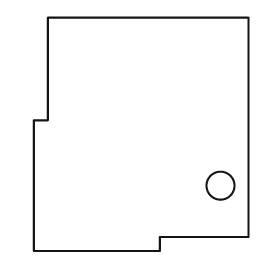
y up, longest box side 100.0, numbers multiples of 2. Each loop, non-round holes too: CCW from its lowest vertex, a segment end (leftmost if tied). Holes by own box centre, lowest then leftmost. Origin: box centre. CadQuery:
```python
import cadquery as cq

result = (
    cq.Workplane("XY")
    .moveTo(-46.0, -50.0)
    .lineTo(8.0, -50.0)
    .lineTo(8.0, -44.0)
    .lineTo(46.0, -44.0)
    .lineTo(46.0, 50.0)
    .lineTo(-40.0, 50.0)
    .lineTo(-40.0, 6.0)
    .lineTo(-46.0, 6.0)
    .close()
    .moveTo(34.0, -22.0)
    .circle(6.0)
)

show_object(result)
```